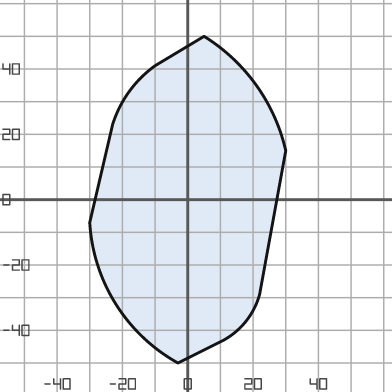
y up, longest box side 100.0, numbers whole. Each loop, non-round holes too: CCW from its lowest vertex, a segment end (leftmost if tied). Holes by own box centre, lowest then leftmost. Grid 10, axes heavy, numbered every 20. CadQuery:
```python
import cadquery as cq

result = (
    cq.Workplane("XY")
    .moveTo(-3.0, -50.0)
    .lineTo(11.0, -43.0)
    .threePointArc((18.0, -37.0), (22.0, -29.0))
    .lineTo(30.0, 15.0)
    .threePointArc((21.0, 35.0), (5.0, 50.0))
    .lineTo(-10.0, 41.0)
    .threePointArc((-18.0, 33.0), (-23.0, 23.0))
    .lineTo(-30.0, -7.0)
    .threePointArc((-22.0, -32.0), (-3.0, -50.0))
    .close()
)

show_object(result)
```